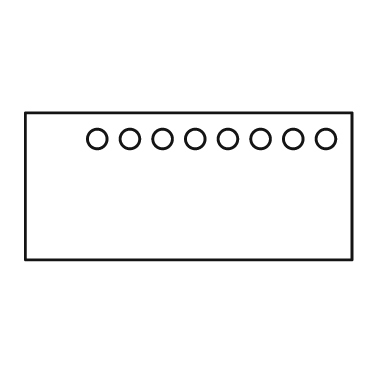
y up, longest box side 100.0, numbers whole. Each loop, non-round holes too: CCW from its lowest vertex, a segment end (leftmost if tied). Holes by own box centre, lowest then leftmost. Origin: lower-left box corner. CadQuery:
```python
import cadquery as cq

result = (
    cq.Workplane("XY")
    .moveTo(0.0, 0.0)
    .lineTo(100.0, 0.0)
    .lineTo(100.0, 45.0)
    .lineTo(0.0, 45.0)
    .close()
    .moveTo(22.0, 37.0)
    .circle(3.0)
    .moveTo(32.0, 37.0)
    .circle(3.0)
    .moveTo(42.0, 37.0)
    .circle(3.0)
    .moveTo(52.0, 37.0)
    .circle(3.0)
    .moveTo(62.0, 37.0)
    .circle(3.0)
    .moveTo(72.0, 37.0)
    .circle(3.0)
    .moveTo(82.0, 37.0)
    .circle(3.0)
    .moveTo(92.0, 37.0)
    .circle(3.0)
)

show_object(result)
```